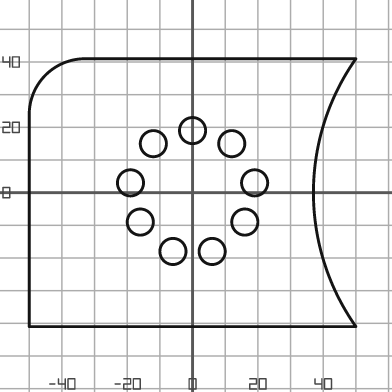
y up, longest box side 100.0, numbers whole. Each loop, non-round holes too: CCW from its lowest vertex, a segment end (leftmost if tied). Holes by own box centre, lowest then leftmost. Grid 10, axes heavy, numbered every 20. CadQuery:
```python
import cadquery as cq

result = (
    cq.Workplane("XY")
    .moveTo(-50.0, -41.0)
    .lineTo(50.0, -41.0)
    .threePointArc((37.0, 0.0), (50.0, 41.0))
    .lineTo(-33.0, 41.0)
    .threePointArc((-45.0, 36.0), (-50.0, 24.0))
    .close()
    .moveTo(-6.0, -18.0)
    .circle(4.0)
    .moveTo(6.0, -18.0)
    .circle(4.0)
    .moveTo(-16.0, -9.0)
    .circle(4.0)
    .moveTo(16.0, -9.0)
    .circle(4.0)
    .moveTo(-19.0, 3.0)
    .circle(4.0)
    .moveTo(19.0, 3.0)
    .circle(4.0)
    .moveTo(-12.0, 15.0)
    .circle(4.0)
    .moveTo(12.0, 15.0)
    .circle(4.0)
    .moveTo(0.0, 19.0)
    .circle(4.0)
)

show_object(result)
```